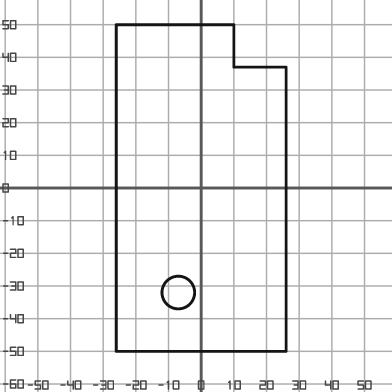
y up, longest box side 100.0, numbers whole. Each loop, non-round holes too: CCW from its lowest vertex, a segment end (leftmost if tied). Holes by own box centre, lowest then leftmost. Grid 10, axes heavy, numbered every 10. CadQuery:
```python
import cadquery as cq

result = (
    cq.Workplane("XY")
    .moveTo(-26.0, -50.0)
    .lineTo(26.0, -50.0)
    .lineTo(26.0, 37.0)
    .lineTo(10.0, 37.0)
    .lineTo(10.0, 50.0)
    .lineTo(-26.0, 50.0)
    .close()
    .moveTo(-7.0, -32.0)
    .circle(5.0)
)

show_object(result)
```